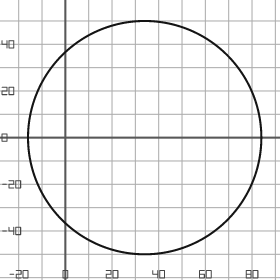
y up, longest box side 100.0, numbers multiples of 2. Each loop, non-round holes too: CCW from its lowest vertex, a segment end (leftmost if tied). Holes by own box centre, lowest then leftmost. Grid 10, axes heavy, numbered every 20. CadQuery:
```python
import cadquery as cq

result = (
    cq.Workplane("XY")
    .moveTo(34.0, 0.0)
    .circle(50.0)
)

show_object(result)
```